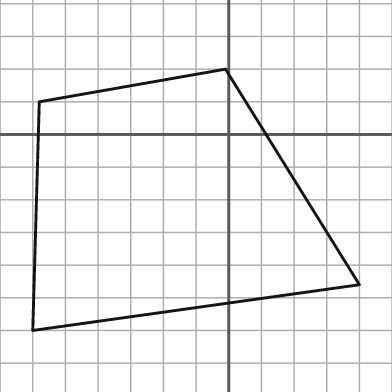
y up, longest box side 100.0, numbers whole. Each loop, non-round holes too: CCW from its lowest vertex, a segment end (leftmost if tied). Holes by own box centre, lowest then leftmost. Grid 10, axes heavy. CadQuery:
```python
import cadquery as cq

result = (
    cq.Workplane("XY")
    .moveTo(-60.0, -60.0)
    .lineTo(40.0, -46.0)
    .lineTo(-1.0, 20.0)
    .lineTo(-58.0, 10.0)
    .close()
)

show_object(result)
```